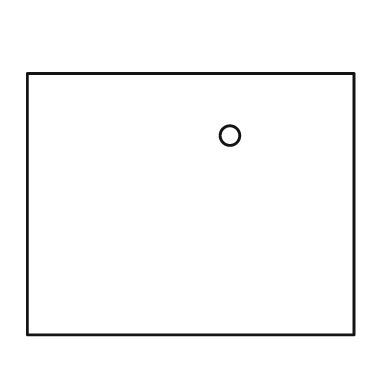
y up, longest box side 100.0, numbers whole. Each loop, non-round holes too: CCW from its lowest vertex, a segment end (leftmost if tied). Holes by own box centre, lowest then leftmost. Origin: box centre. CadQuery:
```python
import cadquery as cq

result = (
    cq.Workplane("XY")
    .moveTo(-50.0, -40.0)
    .lineTo(50.0, -40.0)
    .lineTo(50.0, 40.0)
    .lineTo(-50.0, 40.0)
    .close()
    .moveTo(12.0, 21.0)
    .circle(3.0)
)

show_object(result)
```